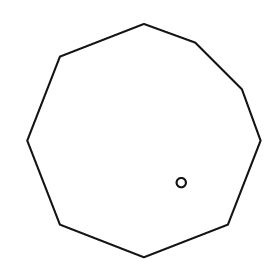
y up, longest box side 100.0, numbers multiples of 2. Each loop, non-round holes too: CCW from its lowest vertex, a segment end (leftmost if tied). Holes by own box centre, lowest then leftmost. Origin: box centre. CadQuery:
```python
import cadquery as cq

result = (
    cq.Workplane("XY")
    .moveTo(0.0, -50.0)
    .lineTo(36.0, -36.0)
    .lineTo(50.0, 0.0)
    .lineTo(42.0, 22.0)
    .lineTo(22.0, 42.0)
    .lineTo(0.0, 50.0)
    .lineTo(-36.0, 36.0)
    .lineTo(-50.0, 0.0)
    .lineTo(-36.0, -36.0)
    .close()
    .moveTo(16.0, -18.0)
    .circle(2.0)
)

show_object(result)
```